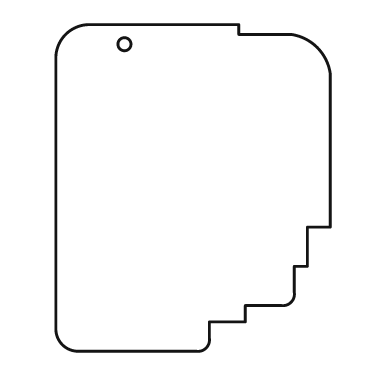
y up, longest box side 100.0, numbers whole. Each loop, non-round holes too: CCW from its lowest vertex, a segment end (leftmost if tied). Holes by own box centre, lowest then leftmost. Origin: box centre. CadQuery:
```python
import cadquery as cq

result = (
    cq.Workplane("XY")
    .moveTo(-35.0, -50.0)
    .lineTo(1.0, -50.0)
    .threePointArc((4.0, -49.0), (5.0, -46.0))
    .lineTo(5.0, -41.0)
    .lineTo(16.0, -41.0)
    .lineTo(16.0, -36.0)
    .lineTo(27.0, -36.0)
    .threePointArc((30.0, -35.0), (31.0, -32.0))
    .lineTo(31.0, -24.0)
    .lineTo(35.0, -24.0)
    .lineTo(35.0, -12.0)
    .lineTo(42.0, -12.0)
    .lineTo(42.0, 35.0)
    .threePointArc((38.0, 43.0), (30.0, 47.0))
    .lineTo(14.0, 47.0)
    .lineTo(14.0, 50.0)
    .lineTo(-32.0, 50.0)
    .threePointArc((-39.0, 47.0), (-42.0, 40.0))
    .lineTo(-42.0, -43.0)
    .threePointArc((-40.0, -48.0), (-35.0, -50.0))
    .close()
    .moveTo(-21.0, 44.0)
    .circle(2.0)
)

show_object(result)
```